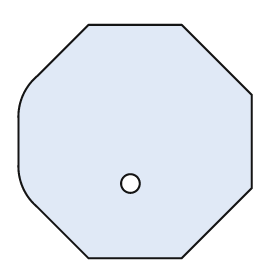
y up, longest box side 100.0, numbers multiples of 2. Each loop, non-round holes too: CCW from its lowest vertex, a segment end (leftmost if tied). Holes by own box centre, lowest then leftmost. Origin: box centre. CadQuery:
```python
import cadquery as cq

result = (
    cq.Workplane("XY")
    .moveTo(-20.0, -50.0)
    .lineTo(20.0, -50.0)
    .lineTo(50.0, -20.0)
    .lineTo(50.0, 20.0)
    .lineTo(20.0, 50.0)
    .lineTo(-20.0, 50.0)
    .lineTo(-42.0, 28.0)
    .threePointArc((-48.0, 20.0), (-50.0, 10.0))
    .lineTo(-50.0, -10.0)
    .threePointArc((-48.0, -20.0), (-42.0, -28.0))
    .close()
    .moveTo(-2.0, -18.0)
    .circle(4.0)
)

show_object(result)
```